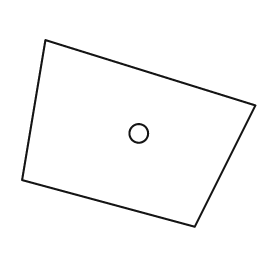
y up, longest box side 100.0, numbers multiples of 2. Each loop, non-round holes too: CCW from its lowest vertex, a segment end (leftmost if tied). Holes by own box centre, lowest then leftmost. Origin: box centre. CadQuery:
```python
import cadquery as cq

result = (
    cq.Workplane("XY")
    .moveTo(24.0, -40.0)
    .lineTo(50.0, 12.0)
    .lineTo(-40.0, 40.0)
    .lineTo(-50.0, -20.0)
    .close()
    .moveTo(0.0, 0.0)
    .circle(4.0)
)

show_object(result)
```